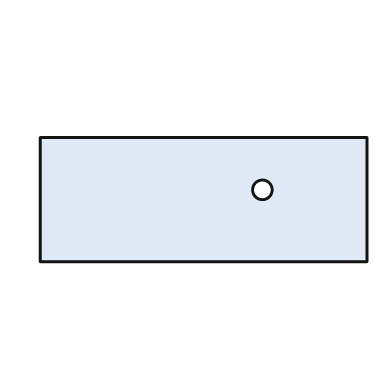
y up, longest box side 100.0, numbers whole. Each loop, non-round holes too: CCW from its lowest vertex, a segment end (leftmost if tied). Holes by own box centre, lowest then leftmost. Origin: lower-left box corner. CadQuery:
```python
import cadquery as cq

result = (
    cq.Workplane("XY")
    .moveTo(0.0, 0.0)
    .lineTo(100.0, 0.0)
    .lineTo(100.0, 38.0)
    .lineTo(0.0, 38.0)
    .close()
    .moveTo(68.0, 22.0)
    .circle(3.0)
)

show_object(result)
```